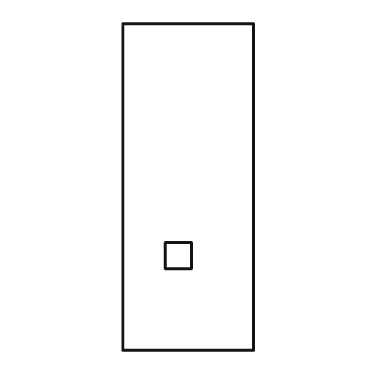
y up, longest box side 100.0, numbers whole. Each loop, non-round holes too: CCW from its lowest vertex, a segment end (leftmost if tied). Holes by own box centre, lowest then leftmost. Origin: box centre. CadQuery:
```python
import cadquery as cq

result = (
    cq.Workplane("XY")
    .moveTo(-20.0, -50.0)
    .lineTo(20.0, -50.0)
    .lineTo(20.0, 50.0)
    .lineTo(-20.0, 50.0)
    .close()
    .moveTo(-7.0, -25.0)
    .lineTo(1.0, -25.0)
    .lineTo(1.0, -17.0)
    .lineTo(-7.0, -17.0)
    .close()
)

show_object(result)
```